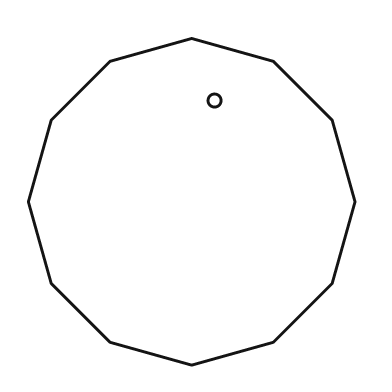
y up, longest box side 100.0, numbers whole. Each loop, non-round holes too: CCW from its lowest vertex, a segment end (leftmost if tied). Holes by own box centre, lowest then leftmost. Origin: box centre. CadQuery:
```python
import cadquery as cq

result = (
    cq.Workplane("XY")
    .moveTo(0.0, -50.0)
    .lineTo(25.0, -43.0)
    .lineTo(43.0, -25.0)
    .lineTo(50.0, 0.0)
    .lineTo(43.0, 25.0)
    .lineTo(25.0, 43.0)
    .lineTo(0.0, 50.0)
    .lineTo(-25.0, 43.0)
    .lineTo(-43.0, 25.0)
    .lineTo(-50.0, 0.0)
    .lineTo(-43.0, -25.0)
    .lineTo(-25.0, -43.0)
    .close()
    .moveTo(7.0, 31.0)
    .circle(2.0)
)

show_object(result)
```